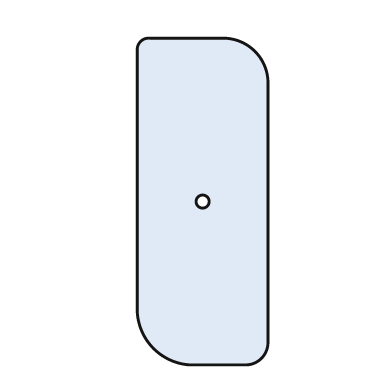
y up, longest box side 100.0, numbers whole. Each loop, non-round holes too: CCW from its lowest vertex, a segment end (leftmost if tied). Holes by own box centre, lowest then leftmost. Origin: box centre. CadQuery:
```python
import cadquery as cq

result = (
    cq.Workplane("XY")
    .moveTo(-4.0, -50.0)
    .lineTo(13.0, -50.0)
    .threePointArc((18.0, -48.0), (20.0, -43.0))
    .lineTo(20.0, 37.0)
    .threePointArc((16.0, 46.0), (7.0, 50.0))
    .lineTo(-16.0, 50.0)
    .threePointArc((-19.0, 49.0), (-20.0, 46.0))
    .lineTo(-20.0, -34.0)
    .threePointArc((-15.0, -45.0), (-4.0, -50.0))
    .close()
    .moveTo(0.0, 0.0)
    .circle(2.0)
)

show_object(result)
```